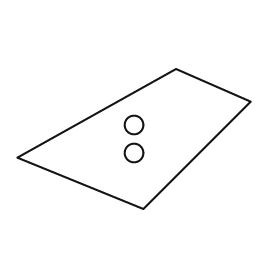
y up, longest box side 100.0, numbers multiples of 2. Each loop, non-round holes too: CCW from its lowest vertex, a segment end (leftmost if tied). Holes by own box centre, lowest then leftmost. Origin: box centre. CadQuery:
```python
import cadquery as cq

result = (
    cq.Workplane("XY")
    .moveTo(4.0, -30.0)
    .lineTo(50.0, 16.0)
    .lineTo(18.0, 30.0)
    .lineTo(-50.0, -8.0)
    .close()
    .moveTo(0.0, -6.0)
    .circle(4.0)
    .moveTo(0.0, 6.0)
    .circle(4.0)
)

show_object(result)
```